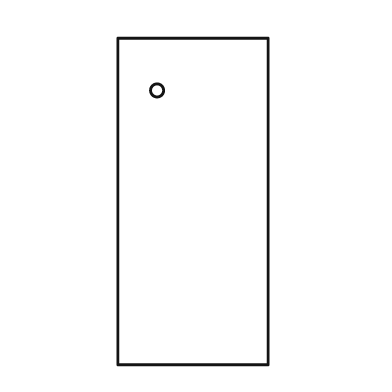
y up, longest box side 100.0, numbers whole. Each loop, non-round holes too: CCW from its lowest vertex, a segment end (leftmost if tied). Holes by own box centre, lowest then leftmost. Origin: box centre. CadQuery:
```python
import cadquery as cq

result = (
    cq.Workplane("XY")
    .moveTo(-23.0, -50.0)
    .lineTo(23.0, -50.0)
    .lineTo(23.0, 50.0)
    .lineTo(-23.0, 50.0)
    .close()
    .moveTo(-11.0, 34.0)
    .circle(2.0)
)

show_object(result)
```